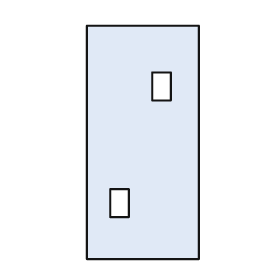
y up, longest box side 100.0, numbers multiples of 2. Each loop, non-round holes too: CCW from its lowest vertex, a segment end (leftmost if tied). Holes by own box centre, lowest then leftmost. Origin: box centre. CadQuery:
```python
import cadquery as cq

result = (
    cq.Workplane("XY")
    .moveTo(-24.0, -50.0)
    .lineTo(24.0, -50.0)
    .lineTo(24.0, 50.0)
    .lineTo(-24.0, 50.0)
    .close()
    .moveTo(-14.0, -32.0)
    .lineTo(-6.0, -32.0)
    .lineTo(-6.0, -20.0)
    .lineTo(-14.0, -20.0)
    .close()
    .moveTo(4.0, 18.0)
    .lineTo(12.0, 18.0)
    .lineTo(12.0, 30.0)
    .lineTo(4.0, 30.0)
    .close()
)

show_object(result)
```